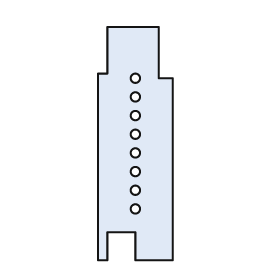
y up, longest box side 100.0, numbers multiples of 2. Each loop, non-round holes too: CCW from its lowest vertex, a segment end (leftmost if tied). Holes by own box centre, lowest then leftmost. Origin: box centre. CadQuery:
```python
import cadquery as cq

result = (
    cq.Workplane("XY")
    .moveTo(-16.0, -50.0)
    .lineTo(-12.0, -50.0)
    .lineTo(-12.0, -38.0)
    .lineTo(0.0, -38.0)
    .lineTo(0.0, -50.0)
    .lineTo(16.0, -50.0)
    .lineTo(16.0, 28.0)
    .lineTo(10.0, 28.0)
    .lineTo(10.0, 50.0)
    .lineTo(-12.0, 50.0)
    .lineTo(-12.0, 30.0)
    .lineTo(-16.0, 30.0)
    .close()
    .moveTo(0.0, -28.0)
    .circle(2.0)
    .moveTo(0.0, -20.0)
    .circle(2.0)
    .moveTo(0.0, -12.0)
    .circle(2.0)
    .moveTo(0.0, -4.0)
    .circle(2.0)
    .moveTo(0.0, 4.0)
    .circle(2.0)
    .moveTo(0.0, 12.0)
    .circle(2.0)
    .moveTo(0.0, 20.0)
    .circle(2.0)
    .moveTo(0.0, 28.0)
    .circle(2.0)
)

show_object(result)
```